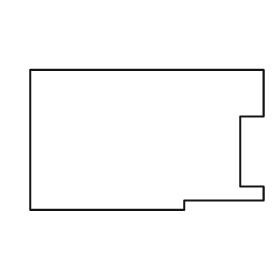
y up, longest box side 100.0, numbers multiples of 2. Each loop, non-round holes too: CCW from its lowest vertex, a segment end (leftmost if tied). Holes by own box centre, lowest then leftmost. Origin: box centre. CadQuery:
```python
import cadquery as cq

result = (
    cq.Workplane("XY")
    .moveTo(-50.0, -30.0)
    .lineTo(16.0, -30.0)
    .lineTo(16.0, -26.0)
    .lineTo(50.0, -26.0)
    .lineTo(50.0, -20.0)
    .lineTo(40.0, -20.0)
    .lineTo(40.0, 10.0)
    .lineTo(50.0, 10.0)
    .lineTo(50.0, 30.0)
    .lineTo(-50.0, 30.0)
    .close()
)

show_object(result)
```